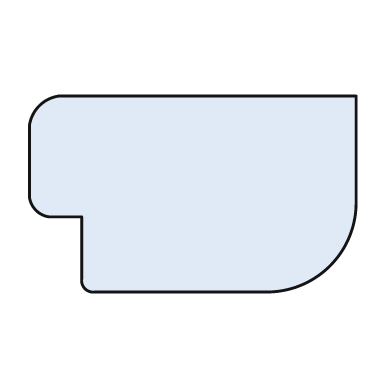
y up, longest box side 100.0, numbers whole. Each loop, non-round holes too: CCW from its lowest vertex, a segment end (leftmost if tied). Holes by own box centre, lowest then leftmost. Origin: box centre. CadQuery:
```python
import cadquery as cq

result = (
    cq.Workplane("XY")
    .moveTo(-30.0, -30.0)
    .lineTo(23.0, -30.0)
    .threePointArc((42.0, -22.0), (50.0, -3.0))
    .lineTo(50.0, 30.0)
    .lineTo(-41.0, 30.0)
    .threePointArc((-47.0, 27.0), (-50.0, 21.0))
    .lineTo(-50.0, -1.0)
    .threePointArc((-48.0, -5.0), (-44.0, -7.0))
    .lineTo(-34.0, -7.0)
    .lineTo(-34.0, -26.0)
    .threePointArc((-33.0, -29.0), (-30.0, -30.0))
    .close()
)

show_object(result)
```